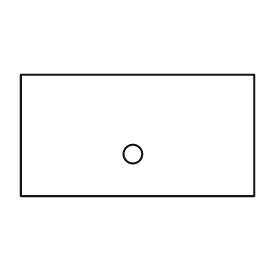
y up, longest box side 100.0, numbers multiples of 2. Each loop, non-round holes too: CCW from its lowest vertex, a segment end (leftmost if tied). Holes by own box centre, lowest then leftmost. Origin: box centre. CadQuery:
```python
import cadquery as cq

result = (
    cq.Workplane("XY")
    .moveTo(-50.0, -26.0)
    .lineTo(50.0, -26.0)
    .lineTo(50.0, 26.0)
    .lineTo(-50.0, 26.0)
    .close()
    .moveTo(-2.0, -8.0)
    .circle(4.0)
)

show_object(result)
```